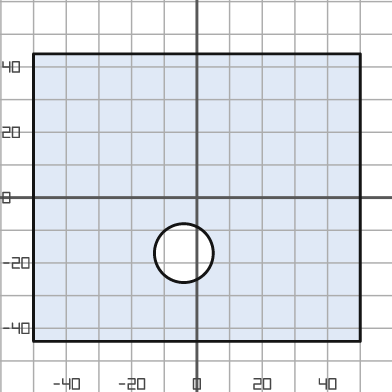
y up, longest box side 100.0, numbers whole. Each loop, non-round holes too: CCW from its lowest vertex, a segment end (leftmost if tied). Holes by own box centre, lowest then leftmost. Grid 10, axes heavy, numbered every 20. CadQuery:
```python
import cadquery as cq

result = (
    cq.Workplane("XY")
    .moveTo(-50.0, -44.0)
    .lineTo(50.0, -44.0)
    .lineTo(50.0, 44.0)
    .lineTo(-50.0, 44.0)
    .close()
    .moveTo(-4.0, -17.0)
    .circle(9.0)
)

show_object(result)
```